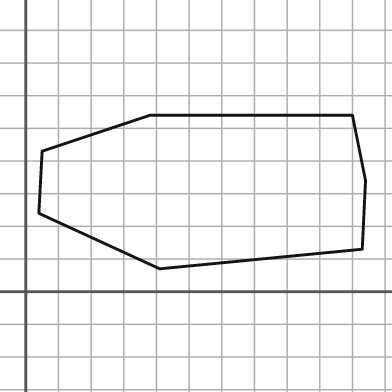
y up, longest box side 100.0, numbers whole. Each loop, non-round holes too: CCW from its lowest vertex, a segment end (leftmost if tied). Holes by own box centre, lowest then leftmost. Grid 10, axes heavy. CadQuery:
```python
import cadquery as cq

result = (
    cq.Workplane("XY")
    .moveTo(41.0, 7.0)
    .lineTo(103.0, 13.0)
    .lineTo(104.0, 34.0)
    .lineTo(100.0, 54.0)
    .lineTo(38.0, 54.0)
    .lineTo(5.0, 43.0)
    .lineTo(4.0, 24.0)
    .close()
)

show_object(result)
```